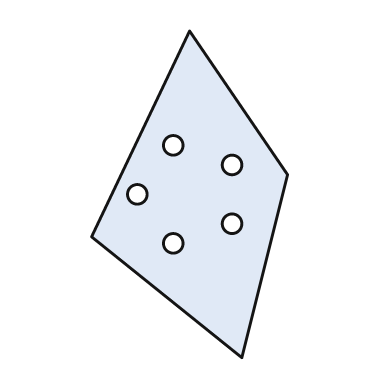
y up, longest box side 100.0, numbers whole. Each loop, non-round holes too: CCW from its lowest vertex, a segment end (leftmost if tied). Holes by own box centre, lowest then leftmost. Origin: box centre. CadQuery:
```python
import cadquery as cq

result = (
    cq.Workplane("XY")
    .moveTo(16.0, -50.0)
    .lineTo(30.0, 6.0)
    .lineTo(0.0, 50.0)
    .lineTo(-30.0, -13.0)
    .close()
    .moveTo(-5.0, -15.0)
    .circle(3.0)
    .moveTo(13.0, -9.0)
    .circle(3.0)
    .moveTo(-16.0, 0.0)
    .circle(3.0)
    .moveTo(13.0, 9.0)
    .circle(3.0)
    .moveTo(-5.0, 15.0)
    .circle(3.0)
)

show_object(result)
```